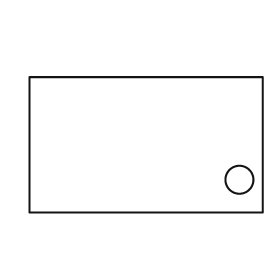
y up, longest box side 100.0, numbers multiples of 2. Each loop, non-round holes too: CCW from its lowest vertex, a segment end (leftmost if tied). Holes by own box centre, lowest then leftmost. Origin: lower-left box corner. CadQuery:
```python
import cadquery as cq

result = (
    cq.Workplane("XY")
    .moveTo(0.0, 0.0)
    .lineTo(100.0, 0.0)
    .lineTo(100.0, 58.0)
    .lineTo(0.0, 58.0)
    .close()
    .moveTo(90.0, 14.0)
    .circle(6.0)
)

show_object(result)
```